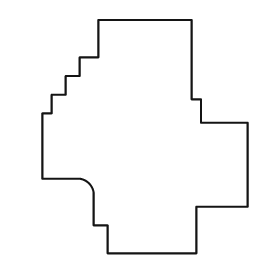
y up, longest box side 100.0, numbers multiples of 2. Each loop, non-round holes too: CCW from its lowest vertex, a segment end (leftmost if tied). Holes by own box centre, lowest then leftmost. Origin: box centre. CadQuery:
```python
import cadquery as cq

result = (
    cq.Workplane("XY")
    .moveTo(-16.0, -50.0)
    .lineTo(22.0, -50.0)
    .lineTo(22.0, -30.0)
    .lineTo(44.0, -30.0)
    .lineTo(44.0, 6.0)
    .lineTo(24.0, 6.0)
    .lineTo(24.0, 16.0)
    .lineTo(20.0, 16.0)
    .lineTo(20.0, 50.0)
    .lineTo(-20.0, 50.0)
    .lineTo(-20.0, 34.0)
    .lineTo(-28.0, 34.0)
    .lineTo(-28.0, 26.0)
    .lineTo(-34.0, 26.0)
    .lineTo(-34.0, 18.0)
    .lineTo(-40.0, 18.0)
    .lineTo(-40.0, 10.0)
    .lineTo(-44.0, 10.0)
    .lineTo(-44.0, -18.0)
    .lineTo(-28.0, -18.0)
    .threePointArc((-24.0, -20.0), (-22.0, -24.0))
    .lineTo(-22.0, -38.0)
    .lineTo(-16.0, -38.0)
    .close()
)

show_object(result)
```